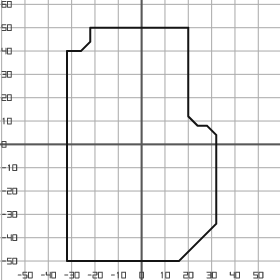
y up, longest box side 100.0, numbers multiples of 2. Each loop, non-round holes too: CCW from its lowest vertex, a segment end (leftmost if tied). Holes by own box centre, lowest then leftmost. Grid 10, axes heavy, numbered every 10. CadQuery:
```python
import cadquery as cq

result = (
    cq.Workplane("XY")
    .moveTo(-32.0, -50.0)
    .lineTo(16.0, -50.0)
    .lineTo(32.0, -34.0)
    .lineTo(32.0, 4.0)
    .lineTo(28.0, 8.0)
    .lineTo(24.0, 8.0)
    .lineTo(20.0, 12.0)
    .lineTo(20.0, 50.0)
    .lineTo(-22.0, 50.0)
    .lineTo(-22.0, 44.0)
    .lineTo(-26.0, 40.0)
    .lineTo(-32.0, 40.0)
    .close()
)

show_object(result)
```